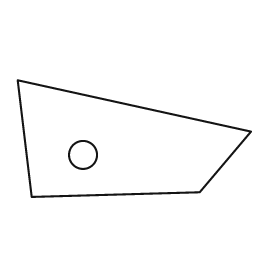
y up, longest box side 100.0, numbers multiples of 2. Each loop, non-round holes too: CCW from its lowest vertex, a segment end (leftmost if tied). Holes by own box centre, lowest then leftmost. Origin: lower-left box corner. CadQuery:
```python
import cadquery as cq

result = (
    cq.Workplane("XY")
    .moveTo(6.0, 0.0)
    .lineTo(78.0, 2.0)
    .lineTo(100.0, 28.0)
    .lineTo(0.0, 50.0)
    .close()
    .moveTo(28.0, 18.0)
    .circle(6.0)
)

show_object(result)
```